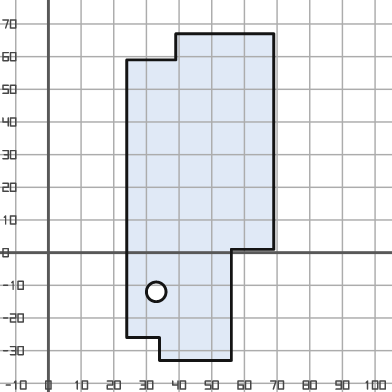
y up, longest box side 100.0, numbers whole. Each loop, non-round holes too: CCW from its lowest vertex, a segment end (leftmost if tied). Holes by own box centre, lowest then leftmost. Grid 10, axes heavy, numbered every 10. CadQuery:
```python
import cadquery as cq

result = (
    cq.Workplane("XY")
    .moveTo(34.0, -33.0)
    .lineTo(56.0, -33.0)
    .lineTo(56.0, 1.0)
    .lineTo(69.0, 1.0)
    .lineTo(69.0, 67.0)
    .lineTo(39.0, 67.0)
    .lineTo(39.0, 59.0)
    .lineTo(24.0, 59.0)
    .lineTo(24.0, -26.0)
    .lineTo(34.0, -26.0)
    .close()
    .moveTo(33.0, -12.0)
    .circle(3.0)
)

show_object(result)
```